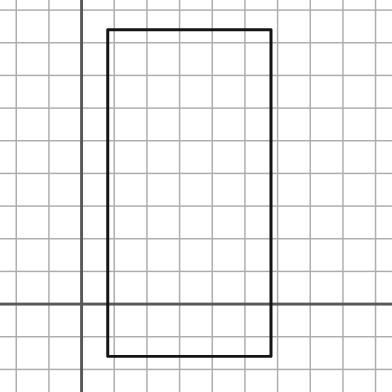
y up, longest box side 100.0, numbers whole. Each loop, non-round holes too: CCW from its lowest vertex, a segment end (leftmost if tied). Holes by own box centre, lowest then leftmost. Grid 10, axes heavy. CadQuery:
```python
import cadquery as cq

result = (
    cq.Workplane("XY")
    .moveTo(8.0, -16.0)
    .lineTo(58.0, -16.0)
    .lineTo(58.0, 84.0)
    .lineTo(8.0, 84.0)
    .close()
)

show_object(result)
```